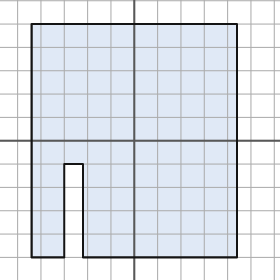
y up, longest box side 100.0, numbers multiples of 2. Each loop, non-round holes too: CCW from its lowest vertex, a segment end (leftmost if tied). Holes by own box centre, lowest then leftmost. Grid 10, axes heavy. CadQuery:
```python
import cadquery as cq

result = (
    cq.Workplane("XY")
    .moveTo(-44.0, -50.0)
    .lineTo(-30.0, -50.0)
    .lineTo(-30.0, -10.0)
    .lineTo(-22.0, -10.0)
    .lineTo(-22.0, -50.0)
    .lineTo(44.0, -50.0)
    .lineTo(44.0, 50.0)
    .lineTo(-44.0, 50.0)
    .close()
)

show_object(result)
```